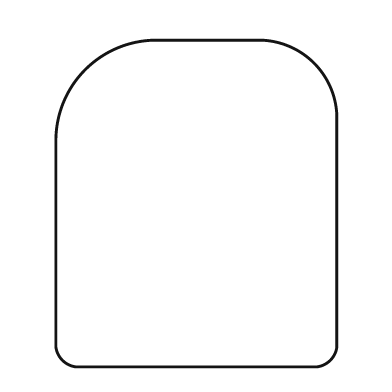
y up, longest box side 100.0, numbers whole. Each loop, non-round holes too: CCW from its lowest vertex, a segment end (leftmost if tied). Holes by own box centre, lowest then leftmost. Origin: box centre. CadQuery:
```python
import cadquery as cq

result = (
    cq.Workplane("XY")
    .moveTo(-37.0, -50.0)
    .lineTo(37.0, -50.0)
    .threePointArc((41.0, -48.0), (43.0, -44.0))
    .lineTo(43.0, 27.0)
    .threePointArc((36.0, 43.0), (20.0, 50.0))
    .lineTo(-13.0, 50.0)
    .threePointArc((-34.0, 41.0), (-43.0, 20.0))
    .lineTo(-43.0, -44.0)
    .threePointArc((-41.0, -48.0), (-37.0, -50.0))
    .close()
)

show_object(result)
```